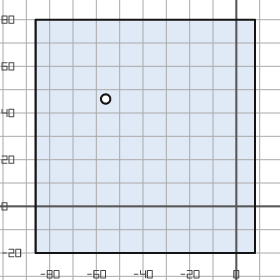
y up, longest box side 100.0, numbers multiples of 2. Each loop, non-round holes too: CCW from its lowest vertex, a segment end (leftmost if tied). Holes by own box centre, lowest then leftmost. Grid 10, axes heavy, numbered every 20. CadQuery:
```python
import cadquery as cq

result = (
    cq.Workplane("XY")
    .moveTo(-86.0, -20.0)
    .lineTo(8.0, -20.0)
    .lineTo(8.0, 80.0)
    .lineTo(-86.0, 80.0)
    .close()
    .moveTo(-56.0, 46.0)
    .circle(2.0)
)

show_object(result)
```